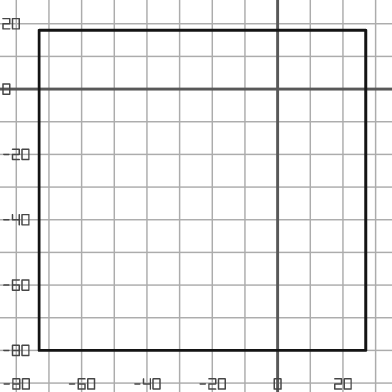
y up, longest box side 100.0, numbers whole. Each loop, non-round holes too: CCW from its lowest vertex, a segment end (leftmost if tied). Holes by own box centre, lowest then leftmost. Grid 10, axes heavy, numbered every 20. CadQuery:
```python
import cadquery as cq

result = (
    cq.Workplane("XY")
    .moveTo(-73.0, -80.0)
    .lineTo(27.0, -80.0)
    .lineTo(27.0, 18.0)
    .lineTo(-73.0, 18.0)
    .close()
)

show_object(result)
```